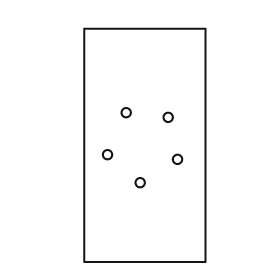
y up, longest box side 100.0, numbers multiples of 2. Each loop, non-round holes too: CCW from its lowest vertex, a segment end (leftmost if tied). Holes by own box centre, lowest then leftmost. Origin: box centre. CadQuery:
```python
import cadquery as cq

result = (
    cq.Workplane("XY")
    .moveTo(-26.0, -50.0)
    .lineTo(26.0, -50.0)
    .lineTo(26.0, 50.0)
    .lineTo(-26.0, 50.0)
    .close()
    .moveTo(-2.0, -16.0)
    .circle(2.0)
    .moveTo(14.0, -6.0)
    .circle(2.0)
    .moveTo(-16.0, -4.0)
    .circle(2.0)
    .moveTo(10.0, 12.0)
    .circle(2.0)
    .moveTo(-8.0, 14.0)
    .circle(2.0)
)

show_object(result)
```